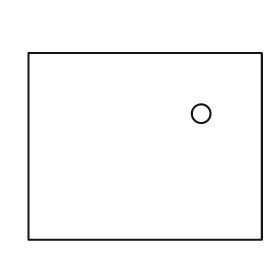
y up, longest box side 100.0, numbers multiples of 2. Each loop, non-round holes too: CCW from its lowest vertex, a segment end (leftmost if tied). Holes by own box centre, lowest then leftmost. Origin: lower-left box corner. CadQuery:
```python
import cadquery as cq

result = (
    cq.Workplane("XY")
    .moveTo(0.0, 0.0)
    .lineTo(100.0, 0.0)
    .lineTo(100.0, 80.0)
    .lineTo(0.0, 80.0)
    .close()
    .moveTo(74.0, 54.0)
    .circle(4.0)
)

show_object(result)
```